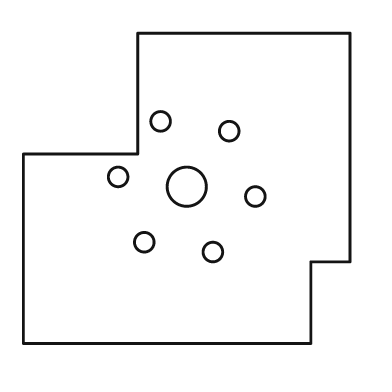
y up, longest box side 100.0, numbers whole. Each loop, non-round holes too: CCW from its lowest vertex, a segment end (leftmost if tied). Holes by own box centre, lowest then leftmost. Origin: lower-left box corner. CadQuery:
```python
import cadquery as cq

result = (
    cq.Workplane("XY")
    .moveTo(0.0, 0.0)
    .lineTo(88.0, 0.0)
    .lineTo(88.0, 25.0)
    .lineTo(100.0, 25.0)
    .lineTo(100.0, 95.0)
    .lineTo(35.0, 95.0)
    .lineTo(35.0, 58.0)
    .lineTo(0.0, 58.0)
    .close()
    .moveTo(58.0, 28.0)
    .circle(3.0)
    .moveTo(37.0, 31.0)
    .circle(3.0)
    .moveTo(71.0, 45.0)
    .circle(3.0)
    .moveTo(50.0, 48.0)
    .circle(6.0)
    .moveTo(29.0, 51.0)
    .circle(3.0)
    .moveTo(63.0, 65.0)
    .circle(3.0)
    .moveTo(42.0, 68.0)
    .circle(3.0)
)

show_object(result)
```